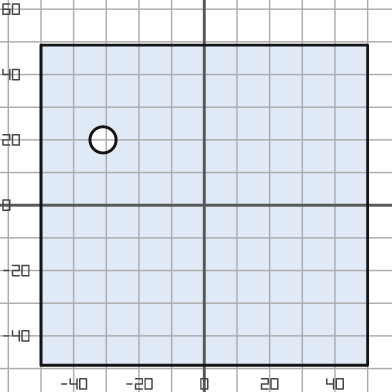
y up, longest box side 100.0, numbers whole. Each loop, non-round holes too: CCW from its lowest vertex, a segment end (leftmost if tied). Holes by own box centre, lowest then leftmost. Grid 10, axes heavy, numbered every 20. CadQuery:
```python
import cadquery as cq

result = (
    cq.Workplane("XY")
    .moveTo(-50.0, -49.0)
    .lineTo(50.0, -49.0)
    .lineTo(50.0, 49.0)
    .lineTo(-50.0, 49.0)
    .close()
    .moveTo(-31.0, 20.0)
    .circle(4.0)
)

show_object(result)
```